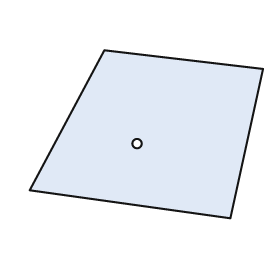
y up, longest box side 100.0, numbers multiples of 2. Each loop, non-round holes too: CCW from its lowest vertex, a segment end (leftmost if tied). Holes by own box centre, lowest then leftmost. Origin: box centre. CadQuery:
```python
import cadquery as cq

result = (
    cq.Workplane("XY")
    .moveTo(36.0, -36.0)
    .lineTo(50.0, 28.0)
    .lineTo(-18.0, 36.0)
    .lineTo(-50.0, -24.0)
    .close()
    .moveTo(-4.0, -4.0)
    .circle(2.0)
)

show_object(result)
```